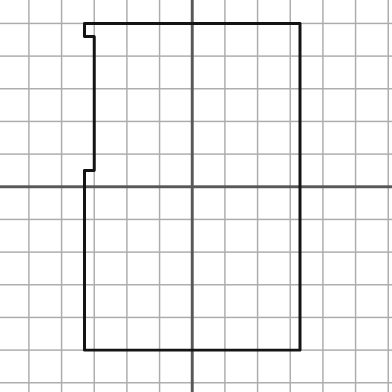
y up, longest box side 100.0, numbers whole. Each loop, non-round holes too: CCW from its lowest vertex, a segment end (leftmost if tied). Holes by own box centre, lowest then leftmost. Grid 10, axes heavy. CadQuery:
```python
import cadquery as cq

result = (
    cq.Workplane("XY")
    .moveTo(-33.0, -50.0)
    .lineTo(33.0, -50.0)
    .lineTo(33.0, 50.0)
    .lineTo(-33.0, 50.0)
    .lineTo(-33.0, 46.0)
    .lineTo(-30.0, 46.0)
    .lineTo(-30.0, 5.0)
    .lineTo(-33.0, 5.0)
    .close()
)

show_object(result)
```